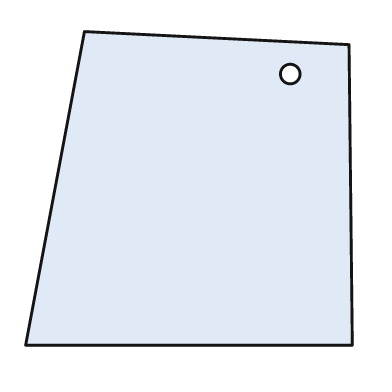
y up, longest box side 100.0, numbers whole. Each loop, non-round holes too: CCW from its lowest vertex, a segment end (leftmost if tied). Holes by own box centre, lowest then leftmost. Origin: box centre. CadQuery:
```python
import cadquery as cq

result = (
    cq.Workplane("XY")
    .moveTo(-50.0, -48.0)
    .lineTo(50.0, -48.0)
    .lineTo(49.0, 44.0)
    .lineTo(-32.0, 48.0)
    .close()
    .moveTo(31.0, 35.0)
    .circle(3.0)
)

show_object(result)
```